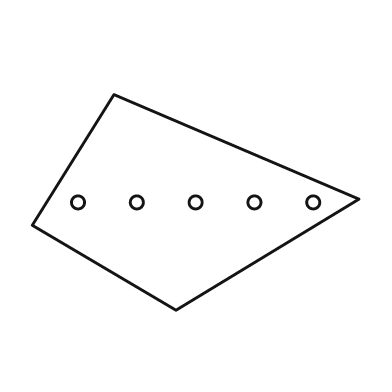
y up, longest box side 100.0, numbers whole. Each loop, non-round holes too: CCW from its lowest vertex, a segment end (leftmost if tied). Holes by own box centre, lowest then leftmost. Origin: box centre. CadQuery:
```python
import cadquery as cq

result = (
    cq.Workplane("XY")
    .moveTo(-6.0, -33.0)
    .lineTo(50.0, 1.0)
    .lineTo(-25.0, 33.0)
    .lineTo(-50.0, -7.0)
    .close()
    .moveTo(-36.0, 0.0)
    .circle(2.0)
    .moveTo(-18.0, 0.0)
    .circle(2.0)
    .moveTo(0.0, 0.0)
    .circle(2.0)
    .moveTo(18.0, 0.0)
    .circle(2.0)
    .moveTo(36.0, 0.0)
    .circle(2.0)
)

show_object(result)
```